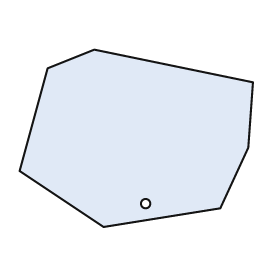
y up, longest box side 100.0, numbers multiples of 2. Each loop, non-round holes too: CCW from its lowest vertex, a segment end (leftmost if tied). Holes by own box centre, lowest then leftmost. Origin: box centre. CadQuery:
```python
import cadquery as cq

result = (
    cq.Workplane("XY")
    .moveTo(-14.0, -38.0)
    .lineTo(36.0, -30.0)
    .lineTo(48.0, -4.0)
    .lineTo(50.0, 24.0)
    .lineTo(-18.0, 38.0)
    .lineTo(-38.0, 30.0)
    .lineTo(-50.0, -14.0)
    .close()
    .moveTo(4.0, -28.0)
    .circle(2.0)
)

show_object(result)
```